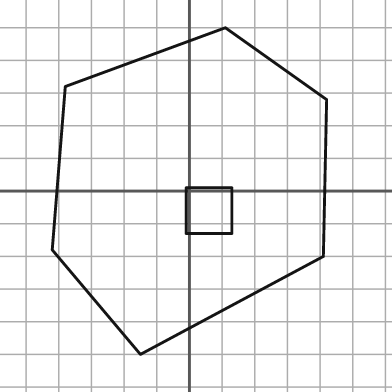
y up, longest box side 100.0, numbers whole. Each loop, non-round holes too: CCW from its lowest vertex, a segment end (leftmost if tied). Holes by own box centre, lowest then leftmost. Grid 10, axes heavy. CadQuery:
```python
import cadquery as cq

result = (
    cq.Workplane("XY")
    .moveTo(-15.0, -50.0)
    .lineTo(41.0, -20.0)
    .lineTo(42.0, 28.0)
    .lineTo(11.0, 50.0)
    .lineTo(-38.0, 32.0)
    .lineTo(-42.0, -18.0)
    .close()
    .moveTo(-1.0, -13.0)
    .lineTo(13.0, -13.0)
    .lineTo(13.0, 1.0)
    .lineTo(-1.0, 1.0)
    .close()
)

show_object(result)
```